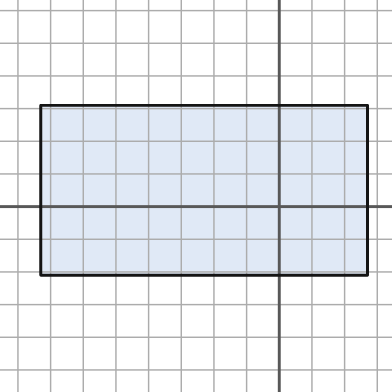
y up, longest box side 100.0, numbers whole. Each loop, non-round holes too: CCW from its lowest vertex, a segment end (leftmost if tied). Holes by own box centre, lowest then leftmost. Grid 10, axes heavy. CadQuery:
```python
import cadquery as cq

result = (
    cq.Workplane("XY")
    .moveTo(-73.0, -21.0)
    .lineTo(27.0, -21.0)
    .lineTo(27.0, 31.0)
    .lineTo(-73.0, 31.0)
    .close()
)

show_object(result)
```